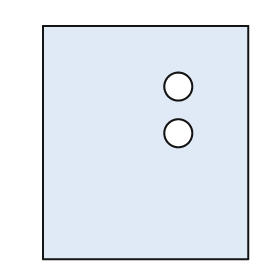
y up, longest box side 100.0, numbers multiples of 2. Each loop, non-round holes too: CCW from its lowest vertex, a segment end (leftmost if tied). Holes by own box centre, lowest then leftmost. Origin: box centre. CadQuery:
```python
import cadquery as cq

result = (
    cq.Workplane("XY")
    .moveTo(-44.0, -50.0)
    .lineTo(44.0, -50.0)
    .lineTo(44.0, 50.0)
    .lineTo(-44.0, 50.0)
    .close()
    .moveTo(14.0, 4.0)
    .circle(6.0)
    .moveTo(14.0, 24.0)
    .circle(6.0)
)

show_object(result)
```